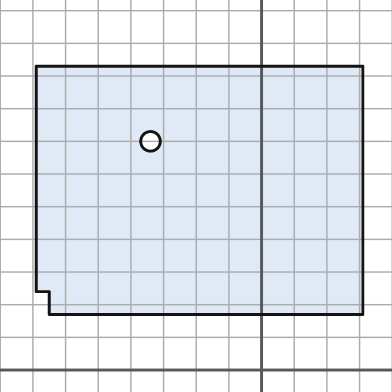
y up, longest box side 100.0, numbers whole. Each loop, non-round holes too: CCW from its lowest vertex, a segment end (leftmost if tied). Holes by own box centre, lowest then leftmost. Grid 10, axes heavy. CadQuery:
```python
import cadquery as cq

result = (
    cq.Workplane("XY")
    .moveTo(-65.0, 17.0)
    .lineTo(31.0, 17.0)
    .lineTo(31.0, 93.0)
    .lineTo(-69.0, 93.0)
    .lineTo(-69.0, 24.0)
    .lineTo(-65.0, 24.0)
    .close()
    .moveTo(-34.0, 70.0)
    .circle(3.0)
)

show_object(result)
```